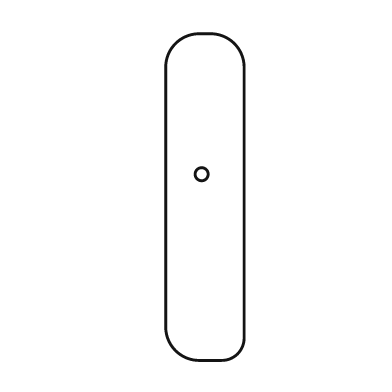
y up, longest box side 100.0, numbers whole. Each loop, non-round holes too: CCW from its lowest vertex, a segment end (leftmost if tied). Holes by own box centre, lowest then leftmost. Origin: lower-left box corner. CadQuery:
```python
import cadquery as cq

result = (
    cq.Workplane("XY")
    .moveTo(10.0, 0.0)
    .lineTo(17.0, 0.0)
    .threePointArc((22.0, 2.0), (24.0, 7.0))
    .lineTo(24.0, 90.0)
    .threePointArc((21.0, 97.0), (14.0, 100.0))
    .lineTo(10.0, 100.0)
    .threePointArc((3.0, 97.0), (0.0, 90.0))
    .lineTo(0.0, 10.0)
    .threePointArc((3.0, 3.0), (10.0, 0.0))
    .close()
    .moveTo(11.0, 57.0)
    .circle(2.0)
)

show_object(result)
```